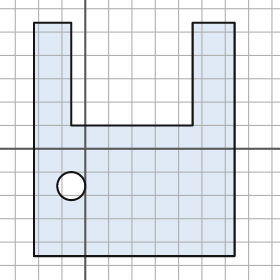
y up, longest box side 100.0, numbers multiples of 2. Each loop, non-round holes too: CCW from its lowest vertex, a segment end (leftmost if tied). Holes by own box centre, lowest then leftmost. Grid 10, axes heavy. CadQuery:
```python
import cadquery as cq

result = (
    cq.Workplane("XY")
    .moveTo(-22.0, -46.0)
    .lineTo(64.0, -46.0)
    .lineTo(64.0, 54.0)
    .lineTo(46.0, 54.0)
    .lineTo(46.0, 10.0)
    .lineTo(-6.0, 10.0)
    .lineTo(-6.0, 54.0)
    .lineTo(-22.0, 54.0)
    .close()
    .moveTo(-6.0, -16.0)
    .circle(6.0)
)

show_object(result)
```